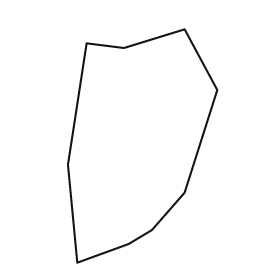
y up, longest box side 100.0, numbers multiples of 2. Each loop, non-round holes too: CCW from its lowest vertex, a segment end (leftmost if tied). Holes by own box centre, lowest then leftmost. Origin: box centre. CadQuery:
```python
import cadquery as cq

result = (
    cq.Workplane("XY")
    .moveTo(-28.0, -50.0)
    .lineTo(-6.0, -42.0)
    .lineTo(4.0, -36.0)
    .lineTo(18.0, -20.0)
    .lineTo(32.0, 24.0)
    .lineTo(18.0, 50.0)
    .lineTo(-8.0, 42.0)
    .lineTo(-24.0, 44.0)
    .lineTo(-32.0, -8.0)
    .close()
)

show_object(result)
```